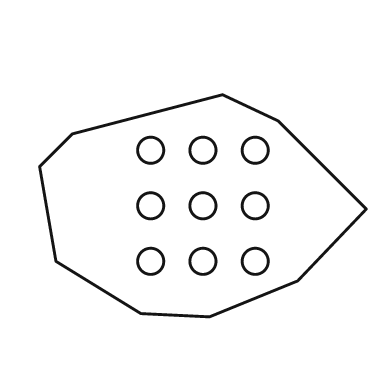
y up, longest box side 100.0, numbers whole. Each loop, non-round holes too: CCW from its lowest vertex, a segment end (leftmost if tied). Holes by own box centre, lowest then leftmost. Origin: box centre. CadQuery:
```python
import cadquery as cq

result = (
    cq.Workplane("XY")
    .moveTo(2.0, -34.0)
    .lineTo(29.0, -23.0)
    .lineTo(50.0, -1.0)
    .lineTo(23.0, 26.0)
    .lineTo(6.0, 34.0)
    .lineTo(-40.0, 22.0)
    .lineTo(-50.0, 12.0)
    .lineTo(-45.0, -17.0)
    .lineTo(-19.0, -33.0)
    .close()
    .moveTo(-16.0, -17.0)
    .circle(4.0)
    .moveTo(0.0, -17.0)
    .circle(4.0)
    .moveTo(16.0, -17.0)
    .circle(4.0)
    .moveTo(-16.0, 0.0)
    .circle(4.0)
    .moveTo(0.0, 0.0)
    .circle(4.0)
    .moveTo(16.0, 0.0)
    .circle(4.0)
    .moveTo(-16.0, 17.0)
    .circle(4.0)
    .moveTo(0.0, 17.0)
    .circle(4.0)
    .moveTo(16.0, 17.0)
    .circle(4.0)
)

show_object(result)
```